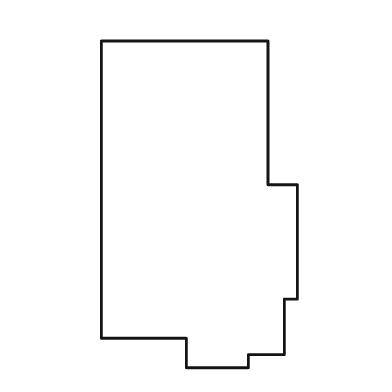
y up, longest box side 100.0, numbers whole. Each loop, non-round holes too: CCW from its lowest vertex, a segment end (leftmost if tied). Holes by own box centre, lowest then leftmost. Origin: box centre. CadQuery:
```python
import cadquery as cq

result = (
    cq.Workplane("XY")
    .moveTo(-4.0, -50.0)
    .lineTo(15.0, -50.0)
    .lineTo(15.0, -46.0)
    .lineTo(26.0, -46.0)
    .lineTo(26.0, -29.0)
    .lineTo(30.0, -29.0)
    .lineTo(30.0, 6.0)
    .lineTo(21.0, 6.0)
    .lineTo(21.0, 50.0)
    .lineTo(-30.0, 50.0)
    .lineTo(-30.0, -41.0)
    .lineTo(-4.0, -41.0)
    .close()
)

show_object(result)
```